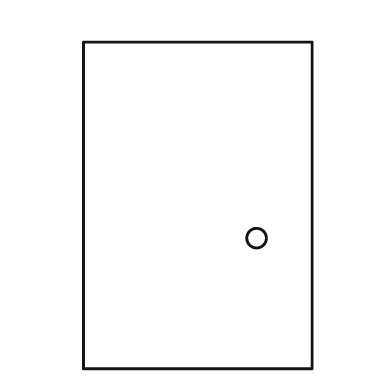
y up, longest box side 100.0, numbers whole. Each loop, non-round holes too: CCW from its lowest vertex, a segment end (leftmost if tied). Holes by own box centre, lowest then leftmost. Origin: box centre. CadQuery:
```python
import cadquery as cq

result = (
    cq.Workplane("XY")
    .moveTo(-35.0, -50.0)
    .lineTo(35.0, -50.0)
    .lineTo(35.0, 50.0)
    .lineTo(-35.0, 50.0)
    .close()
    .moveTo(18.0, -10.0)
    .circle(3.0)
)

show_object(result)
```